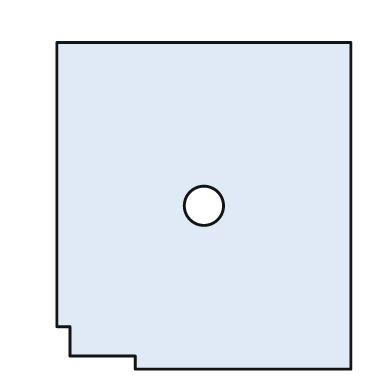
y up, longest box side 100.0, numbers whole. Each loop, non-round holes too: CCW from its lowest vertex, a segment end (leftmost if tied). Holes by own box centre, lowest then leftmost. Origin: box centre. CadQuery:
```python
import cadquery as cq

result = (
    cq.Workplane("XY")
    .moveTo(-21.0, -50.0)
    .lineTo(45.0, -50.0)
    .lineTo(45.0, 50.0)
    .lineTo(-45.0, 50.0)
    .lineTo(-45.0, -37.0)
    .lineTo(-41.0, -37.0)
    .lineTo(-41.0, -46.0)
    .lineTo(-21.0, -46.0)
    .close()
    .moveTo(0.0, 0.0)
    .circle(6.0)
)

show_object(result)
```